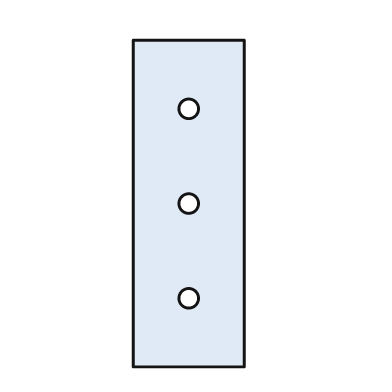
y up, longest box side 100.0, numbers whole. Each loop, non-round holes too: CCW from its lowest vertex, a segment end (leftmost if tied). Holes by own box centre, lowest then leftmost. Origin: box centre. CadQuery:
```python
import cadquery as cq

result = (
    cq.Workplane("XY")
    .moveTo(-17.0, -50.0)
    .lineTo(17.0, -50.0)
    .lineTo(17.0, 50.0)
    .lineTo(-17.0, 50.0)
    .close()
    .moveTo(0.0, -29.0)
    .circle(3.0)
    .moveTo(0.0, 0.0)
    .circle(3.0)
    .moveTo(0.0, 29.0)
    .circle(3.0)
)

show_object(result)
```